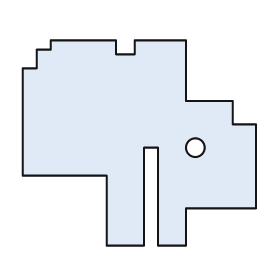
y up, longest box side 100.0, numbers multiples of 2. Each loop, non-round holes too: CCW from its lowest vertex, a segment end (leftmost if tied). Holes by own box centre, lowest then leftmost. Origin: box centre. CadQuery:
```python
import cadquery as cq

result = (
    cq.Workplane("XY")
    .moveTo(-14.0, -44.0)
    .lineTo(2.0, -44.0)
    .lineTo(2.0, -2.0)
    .lineTo(8.0, -2.0)
    .lineTo(8.0, -44.0)
    .lineTo(20.0, -44.0)
    .lineTo(20.0, -28.0)
    .lineTo(50.0, -28.0)
    .lineTo(50.0, 8.0)
    .lineTo(40.0, 8.0)
    .lineTo(40.0, 18.0)
    .lineTo(20.0, 18.0)
    .lineTo(20.0, 44.0)
    .lineTo(-2.0, 44.0)
    .lineTo(-2.0, 38.0)
    .lineTo(-10.0, 38.0)
    .lineTo(-10.0, 44.0)
    .lineTo(-38.0, 44.0)
    .lineTo(-38.0, 40.0)
    .lineTo(-44.0, 40.0)
    .lineTo(-44.0, 32.0)
    .lineTo(-50.0, 32.0)
    .lineTo(-50.0, -14.0)
    .lineTo(-14.0, -14.0)
    .close()
    .moveTo(24.0, -2.0)
    .circle(4.0)
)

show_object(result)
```